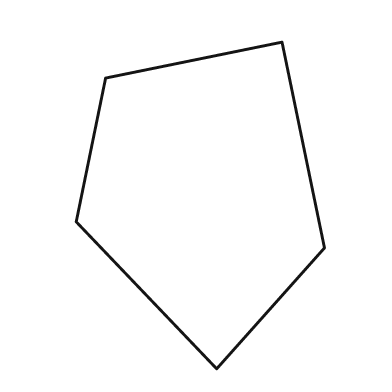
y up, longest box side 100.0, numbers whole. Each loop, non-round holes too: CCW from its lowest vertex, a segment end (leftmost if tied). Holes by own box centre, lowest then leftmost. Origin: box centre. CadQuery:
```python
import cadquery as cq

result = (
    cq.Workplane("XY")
    .moveTo(5.0, -50.0)
    .lineTo(38.0, -13.0)
    .lineTo(25.0, 50.0)
    .lineTo(-29.0, 39.0)
    .lineTo(-38.0, -5.0)
    .close()
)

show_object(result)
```